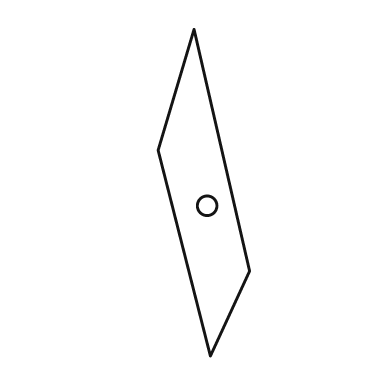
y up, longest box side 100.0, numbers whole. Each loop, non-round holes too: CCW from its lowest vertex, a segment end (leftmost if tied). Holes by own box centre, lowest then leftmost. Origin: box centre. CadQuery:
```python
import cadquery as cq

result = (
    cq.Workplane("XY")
    .moveTo(2.0, -50.0)
    .lineTo(14.0, -24.0)
    .lineTo(-3.0, 50.0)
    .lineTo(-14.0, 13.0)
    .close()
    .moveTo(1.0, -4.0)
    .circle(3.0)
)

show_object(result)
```